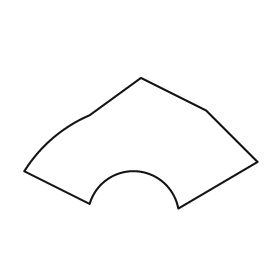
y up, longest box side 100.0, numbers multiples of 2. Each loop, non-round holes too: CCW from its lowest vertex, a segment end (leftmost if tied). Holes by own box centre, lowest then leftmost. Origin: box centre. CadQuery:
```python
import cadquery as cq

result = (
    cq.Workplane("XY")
    .moveTo(16.0, -28.0)
    .lineTo(50.0, -8.0)
    .lineTo(28.0, 14.0)
    .lineTo(0.0, 28.0)
    .lineTo(-22.0, 12.0)
    .threePointArc((-38.0, 2.0), (-50.0, -12.0))
    .lineTo(-22.0, -26.0)
    .threePointArc((-2.0, -12.0), (16.0, -28.0))
    .close()
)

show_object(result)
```